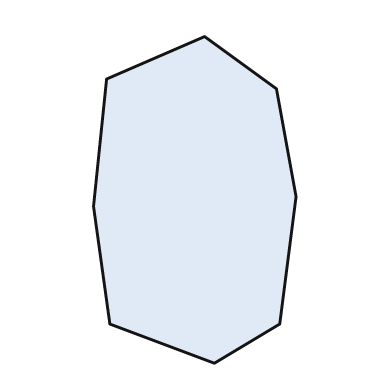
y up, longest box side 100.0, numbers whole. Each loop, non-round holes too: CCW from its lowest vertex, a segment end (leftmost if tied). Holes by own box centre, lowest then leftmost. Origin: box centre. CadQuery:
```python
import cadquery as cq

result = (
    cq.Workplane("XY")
    .moveTo(6.0, -50.0)
    .lineTo(26.0, -38.0)
    .lineTo(31.0, 1.0)
    .lineTo(25.0, 34.0)
    .lineTo(3.0, 50.0)
    .lineTo(-27.0, 37.0)
    .lineTo(-31.0, -2.0)
    .lineTo(-26.0, -38.0)
    .close()
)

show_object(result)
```